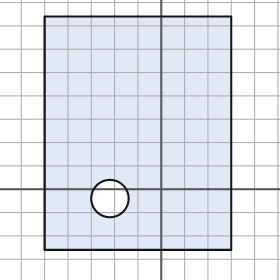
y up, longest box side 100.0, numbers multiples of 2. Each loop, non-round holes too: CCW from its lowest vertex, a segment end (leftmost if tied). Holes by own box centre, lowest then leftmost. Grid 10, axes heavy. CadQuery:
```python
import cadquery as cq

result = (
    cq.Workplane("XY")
    .moveTo(-50.0, -26.0)
    .lineTo(30.0, -26.0)
    .lineTo(30.0, 74.0)
    .lineTo(-50.0, 74.0)
    .close()
    .moveTo(-22.0, -4.0)
    .circle(8.0)
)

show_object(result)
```